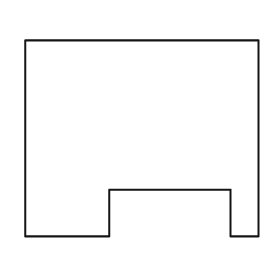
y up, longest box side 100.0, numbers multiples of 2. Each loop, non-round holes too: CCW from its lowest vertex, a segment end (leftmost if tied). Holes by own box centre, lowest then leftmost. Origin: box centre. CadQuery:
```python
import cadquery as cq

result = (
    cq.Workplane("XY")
    .moveTo(-50.0, -42.0)
    .lineTo(-14.0, -42.0)
    .lineTo(-14.0, -22.0)
    .lineTo(38.0, -22.0)
    .lineTo(38.0, -42.0)
    .lineTo(50.0, -42.0)
    .lineTo(50.0, 42.0)
    .lineTo(-50.0, 42.0)
    .close()
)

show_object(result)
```